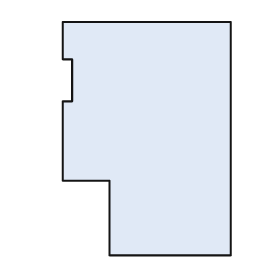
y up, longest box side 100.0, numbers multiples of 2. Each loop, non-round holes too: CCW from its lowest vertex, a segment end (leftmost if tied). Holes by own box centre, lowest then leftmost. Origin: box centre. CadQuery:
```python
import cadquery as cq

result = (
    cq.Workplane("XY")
    .moveTo(-16.0, -50.0)
    .lineTo(36.0, -50.0)
    .lineTo(36.0, 50.0)
    .lineTo(-36.0, 50.0)
    .lineTo(-36.0, 34.0)
    .lineTo(-32.0, 34.0)
    .lineTo(-32.0, 16.0)
    .lineTo(-36.0, 16.0)
    .lineTo(-36.0, -18.0)
    .lineTo(-16.0, -18.0)
    .close()
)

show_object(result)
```